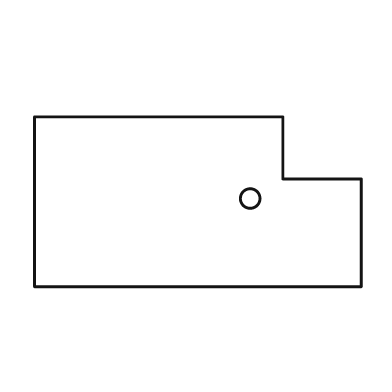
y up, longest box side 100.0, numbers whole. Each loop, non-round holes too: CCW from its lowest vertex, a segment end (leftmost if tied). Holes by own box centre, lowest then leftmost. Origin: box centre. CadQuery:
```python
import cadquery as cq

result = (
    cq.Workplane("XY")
    .moveTo(-50.0, -26.0)
    .lineTo(50.0, -26.0)
    .lineTo(50.0, 7.0)
    .lineTo(26.0, 7.0)
    .lineTo(26.0, 26.0)
    .lineTo(-50.0, 26.0)
    .close()
    .moveTo(16.0, 1.0)
    .circle(3.0)
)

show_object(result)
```